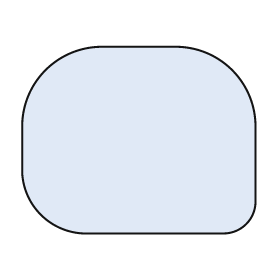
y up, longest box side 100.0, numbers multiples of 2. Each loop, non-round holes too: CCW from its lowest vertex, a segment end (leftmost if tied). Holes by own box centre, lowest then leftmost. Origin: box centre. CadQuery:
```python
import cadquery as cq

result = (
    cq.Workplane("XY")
    .moveTo(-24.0, -40.0)
    .lineTo(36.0, -40.0)
    .threePointArc((46.0, -36.0), (50.0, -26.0))
    .lineTo(50.0, 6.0)
    .threePointArc((40.0, 30.0), (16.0, 40.0))
    .lineTo(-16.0, 40.0)
    .threePointArc((-40.0, 30.0), (-50.0, 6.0))
    .lineTo(-50.0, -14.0)
    .threePointArc((-42.0, -32.0), (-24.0, -40.0))
    .close()
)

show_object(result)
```